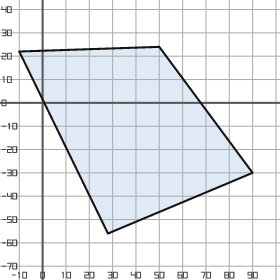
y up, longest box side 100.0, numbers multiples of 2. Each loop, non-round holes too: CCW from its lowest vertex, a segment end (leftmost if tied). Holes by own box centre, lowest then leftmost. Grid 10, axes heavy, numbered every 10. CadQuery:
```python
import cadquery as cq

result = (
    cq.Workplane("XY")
    .moveTo(28.0, -56.0)
    .lineTo(90.0, -30.0)
    .lineTo(50.0, 24.0)
    .lineTo(-10.0, 22.0)
    .close()
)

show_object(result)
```